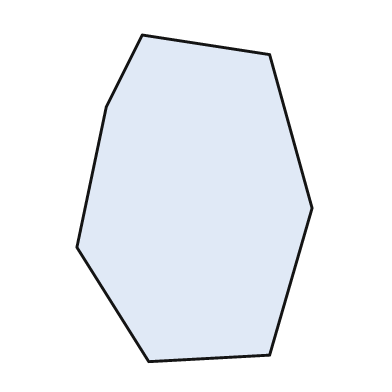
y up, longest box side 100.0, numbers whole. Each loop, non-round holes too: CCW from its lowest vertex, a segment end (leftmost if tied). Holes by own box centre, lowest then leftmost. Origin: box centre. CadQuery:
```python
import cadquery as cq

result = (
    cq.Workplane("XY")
    .moveTo(-14.0, -50.0)
    .lineTo(23.0, -48.0)
    .lineTo(36.0, -3.0)
    .lineTo(23.0, 44.0)
    .lineTo(-16.0, 50.0)
    .lineTo(-27.0, 28.0)
    .lineTo(-36.0, -15.0)
    .close()
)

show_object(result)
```